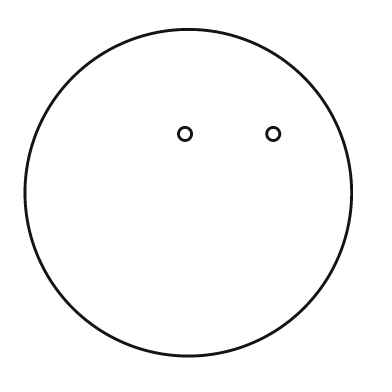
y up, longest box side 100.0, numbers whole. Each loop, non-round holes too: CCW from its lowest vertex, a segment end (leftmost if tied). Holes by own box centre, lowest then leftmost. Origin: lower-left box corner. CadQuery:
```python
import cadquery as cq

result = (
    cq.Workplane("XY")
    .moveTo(50.0, 50.0)
    .circle(50.0)
    .moveTo(49.0, 68.0)
    .circle(2.0)
    .moveTo(76.0, 68.0)
    .circle(2.0)
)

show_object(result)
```